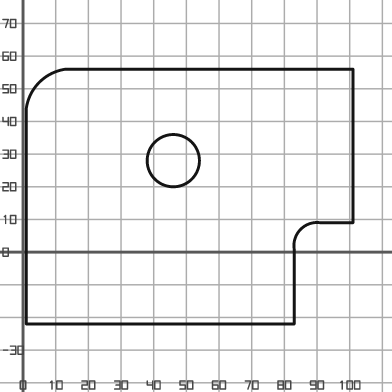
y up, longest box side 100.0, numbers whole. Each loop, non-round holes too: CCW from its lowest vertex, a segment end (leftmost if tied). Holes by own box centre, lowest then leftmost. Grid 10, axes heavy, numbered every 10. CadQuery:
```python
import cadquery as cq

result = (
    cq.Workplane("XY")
    .moveTo(1.0, -22.0)
    .lineTo(83.0, -22.0)
    .lineTo(83.0, 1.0)
    .threePointArc((85.0, 7.0), (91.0, 9.0))
    .lineTo(101.0, 9.0)
    .lineTo(101.0, 56.0)
    .lineTo(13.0, 56.0)
    .threePointArc((5.0, 52.0), (1.0, 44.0))
    .close()
    .moveTo(46.0, 28.0)
    .circle(8.0)
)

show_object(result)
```